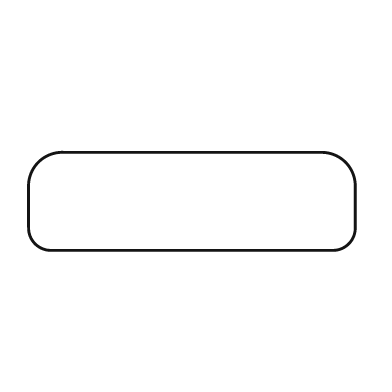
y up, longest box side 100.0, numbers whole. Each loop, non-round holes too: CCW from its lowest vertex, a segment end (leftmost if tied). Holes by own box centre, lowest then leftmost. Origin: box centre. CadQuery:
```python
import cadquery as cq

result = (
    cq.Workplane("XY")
    .moveTo(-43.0, -15.0)
    .lineTo(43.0, -15.0)
    .threePointArc((48.0, -13.0), (50.0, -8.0))
    .lineTo(50.0, 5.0)
    .threePointArc((47.0, 12.0), (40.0, 15.0))
    .lineTo(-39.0, 15.0)
    .threePointArc((-47.0, 12.0), (-50.0, 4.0))
    .lineTo(-50.0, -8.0)
    .threePointArc((-48.0, -13.0), (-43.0, -15.0))
    .close()
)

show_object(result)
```